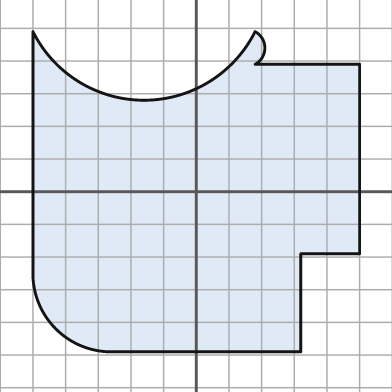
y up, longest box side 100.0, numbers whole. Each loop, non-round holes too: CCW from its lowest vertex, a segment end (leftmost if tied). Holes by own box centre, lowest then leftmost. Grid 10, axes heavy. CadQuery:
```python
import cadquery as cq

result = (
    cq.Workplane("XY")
    .moveTo(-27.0, -49.0)
    .lineTo(32.0, -49.0)
    .lineTo(32.0, -19.0)
    .lineTo(50.0, -19.0)
    .lineTo(50.0, 39.0)
    .lineTo(18.0, 39.0)
    .threePointArc((21.0, 44.0), (18.0, 49.0))
    .threePointArc((-16.0, 28.0), (-50.0, 49.0))
    .lineTo(-50.0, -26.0)
    .threePointArc((-43.0, -42.0), (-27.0, -49.0))
    .close()
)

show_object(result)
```